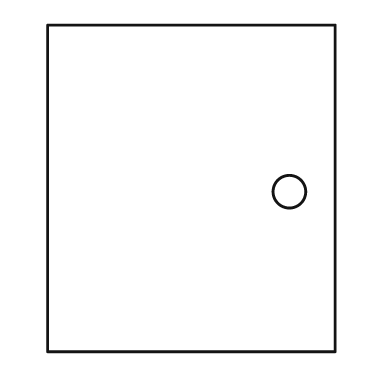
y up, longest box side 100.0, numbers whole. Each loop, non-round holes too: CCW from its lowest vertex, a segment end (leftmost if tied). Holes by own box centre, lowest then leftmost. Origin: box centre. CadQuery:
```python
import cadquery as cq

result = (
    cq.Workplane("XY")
    .moveTo(-44.0, -50.0)
    .lineTo(44.0, -50.0)
    .lineTo(44.0, 50.0)
    .lineTo(-44.0, 50.0)
    .close()
    .moveTo(30.0, -1.0)
    .circle(5.0)
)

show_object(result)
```